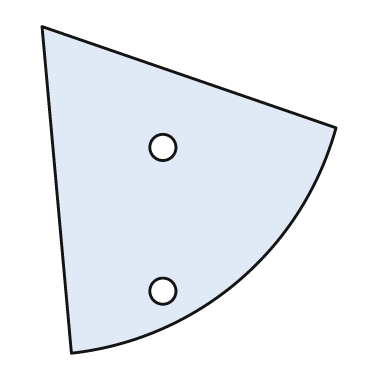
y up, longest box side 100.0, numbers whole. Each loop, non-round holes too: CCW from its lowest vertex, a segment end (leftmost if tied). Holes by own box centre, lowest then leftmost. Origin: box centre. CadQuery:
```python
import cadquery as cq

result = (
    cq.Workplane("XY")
    .moveTo(-36.0, -50.0)
    .threePointArc((15.0, -28.0), (45.0, 19.0))
    .lineTo(-45.0, 50.0)
    .close()
    .moveTo(-8.0, -31.0)
    .circle(4.0)
    .moveTo(-8.0, 13.0)
    .circle(4.0)
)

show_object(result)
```